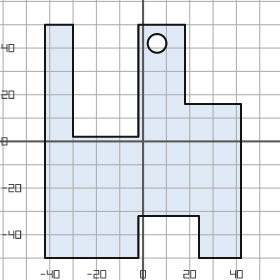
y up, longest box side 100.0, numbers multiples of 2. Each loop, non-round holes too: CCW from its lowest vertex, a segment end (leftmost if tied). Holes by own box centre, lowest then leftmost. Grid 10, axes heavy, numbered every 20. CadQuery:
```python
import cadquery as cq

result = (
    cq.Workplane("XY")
    .moveTo(-42.0, -50.0)
    .lineTo(-2.0, -50.0)
    .lineTo(-2.0, -32.0)
    .lineTo(24.0, -32.0)
    .lineTo(24.0, -50.0)
    .lineTo(42.0, -50.0)
    .lineTo(42.0, 16.0)
    .lineTo(18.0, 16.0)
    .lineTo(18.0, 50.0)
    .lineTo(-2.0, 50.0)
    .lineTo(-2.0, 2.0)
    .lineTo(-30.0, 2.0)
    .lineTo(-30.0, 50.0)
    .lineTo(-42.0, 50.0)
    .close()
    .moveTo(6.0, 42.0)
    .circle(4.0)
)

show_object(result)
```